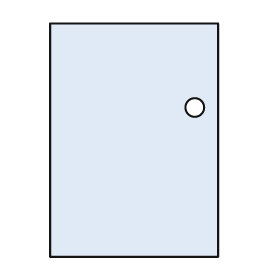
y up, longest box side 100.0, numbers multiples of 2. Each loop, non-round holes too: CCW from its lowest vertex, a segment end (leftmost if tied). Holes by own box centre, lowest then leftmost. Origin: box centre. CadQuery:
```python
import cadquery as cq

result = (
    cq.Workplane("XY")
    .moveTo(-36.0, -50.0)
    .lineTo(36.0, -50.0)
    .lineTo(36.0, 50.0)
    .lineTo(-36.0, 50.0)
    .close()
    .moveTo(26.0, 14.0)
    .circle(4.0)
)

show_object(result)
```